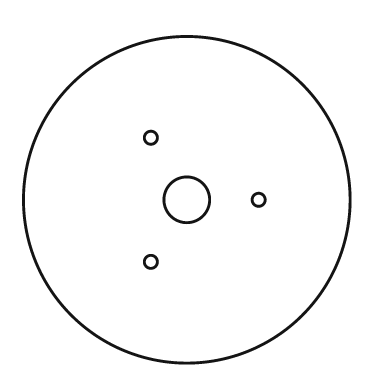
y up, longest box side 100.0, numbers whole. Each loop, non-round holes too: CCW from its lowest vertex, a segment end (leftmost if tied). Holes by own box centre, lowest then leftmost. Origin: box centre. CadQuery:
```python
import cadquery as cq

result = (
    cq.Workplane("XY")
    .moveTo(0.0, 0.0)
    .circle(50.0)
    .moveTo(-11.0, -19.0)
    .circle(2.0)
    .moveTo(0.0, 0.0)
    .circle(7.0)
    .moveTo(22.0, 0.0)
    .circle(2.0)
    .moveTo(-11.0, 19.0)
    .circle(2.0)
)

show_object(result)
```